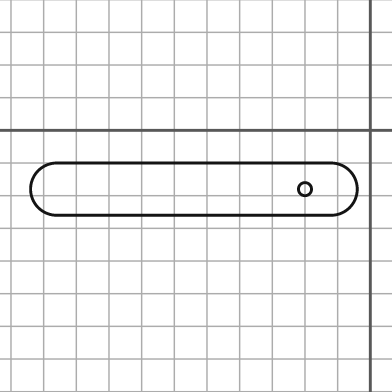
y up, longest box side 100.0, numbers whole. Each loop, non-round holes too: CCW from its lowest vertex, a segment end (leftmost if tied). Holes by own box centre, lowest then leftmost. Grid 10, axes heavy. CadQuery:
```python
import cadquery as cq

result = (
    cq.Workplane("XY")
    .moveTo(-96.0, -26.0)
    .lineTo(-12.0, -26.0)
    .threePointArc((-4.0, -18.0), (-12.0, -10.0))
    .lineTo(-96.0, -10.0)
    .threePointArc((-104.0, -18.0), (-96.0, -26.0))
    .close()
    .moveTo(-20.0, -18.0)
    .circle(2.0)
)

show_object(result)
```